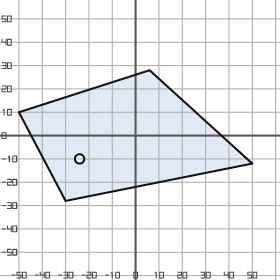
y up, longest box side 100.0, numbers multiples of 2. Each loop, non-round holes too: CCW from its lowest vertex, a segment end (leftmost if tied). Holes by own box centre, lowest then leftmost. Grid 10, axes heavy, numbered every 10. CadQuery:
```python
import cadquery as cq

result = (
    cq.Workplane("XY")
    .moveTo(-30.0, -28.0)
    .lineTo(50.0, -12.0)
    .lineTo(6.0, 28.0)
    .lineTo(-50.0, 10.0)
    .close()
    .moveTo(-24.0, -10.0)
    .circle(2.0)
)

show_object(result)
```